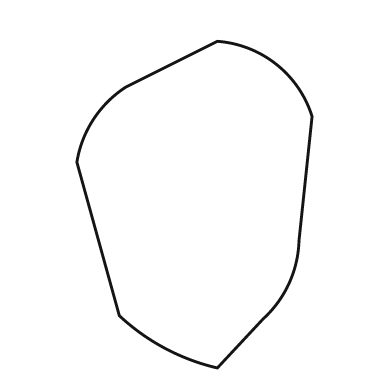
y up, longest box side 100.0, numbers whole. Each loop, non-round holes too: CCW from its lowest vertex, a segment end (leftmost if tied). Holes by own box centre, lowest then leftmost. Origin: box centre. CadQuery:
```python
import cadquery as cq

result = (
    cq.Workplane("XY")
    .moveTo(7.0, -50.0)
    .lineTo(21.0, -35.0)
    .threePointArc((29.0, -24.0), (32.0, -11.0))
    .lineTo(36.0, 27.0)
    .threePointArc((25.0, 43.0), (7.0, 50.0))
    .lineTo(-21.0, 36.0)
    .threePointArc((-31.0, 26.0), (-36.0, 13.0))
    .lineTo(-23.0, -34.0)
    .threePointArc((-9.0, -44.0), (7.0, -50.0))
    .close()
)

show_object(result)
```